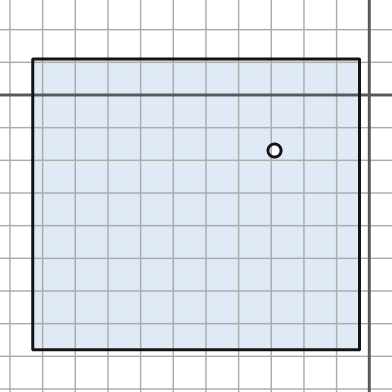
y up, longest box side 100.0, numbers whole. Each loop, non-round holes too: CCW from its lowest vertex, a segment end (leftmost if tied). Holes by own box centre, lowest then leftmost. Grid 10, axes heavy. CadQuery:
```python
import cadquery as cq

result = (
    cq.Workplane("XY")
    .moveTo(-103.0, -78.0)
    .lineTo(-3.0, -78.0)
    .lineTo(-3.0, 11.0)
    .lineTo(-103.0, 11.0)
    .close()
    .moveTo(-29.0, -17.0)
    .circle(2.0)
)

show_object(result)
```